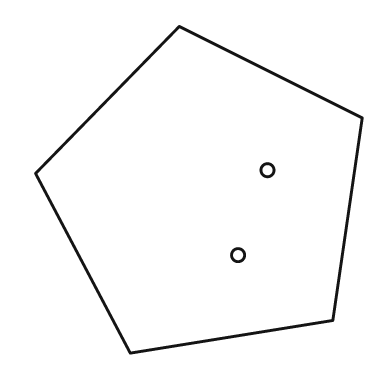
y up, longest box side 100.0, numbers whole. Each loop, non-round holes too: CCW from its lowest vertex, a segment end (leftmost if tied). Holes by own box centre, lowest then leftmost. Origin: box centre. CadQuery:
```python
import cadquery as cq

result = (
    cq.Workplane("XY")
    .moveTo(-21.0, -50.0)
    .lineTo(41.0, -40.0)
    .lineTo(50.0, 22.0)
    .lineTo(-6.0, 50.0)
    .lineTo(-50.0, 5.0)
    .close()
    .moveTo(12.0, -20.0)
    .circle(2.0)
    .moveTo(21.0, 6.0)
    .circle(2.0)
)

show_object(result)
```